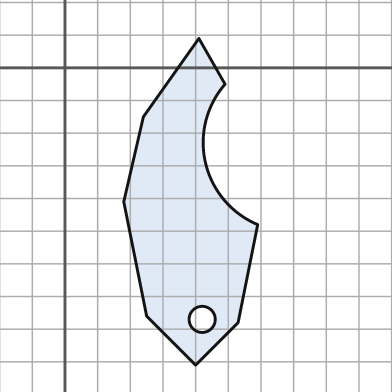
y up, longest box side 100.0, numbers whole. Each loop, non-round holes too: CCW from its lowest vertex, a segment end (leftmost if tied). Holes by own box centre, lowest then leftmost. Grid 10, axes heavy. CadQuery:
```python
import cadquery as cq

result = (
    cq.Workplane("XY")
    .moveTo(40.0, -91.0)
    .lineTo(53.0, -78.0)
    .lineTo(59.0, -48.0)
    .threePointArc((43.0, -29.0), (49.0, -5.0))
    .lineTo(41.0, 9.0)
    .lineTo(24.0, -15.0)
    .lineTo(18.0, -41.0)
    .lineTo(25.0, -76.0)
    .close()
    .moveTo(42.0, -77.0)
    .circle(4.0)
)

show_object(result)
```